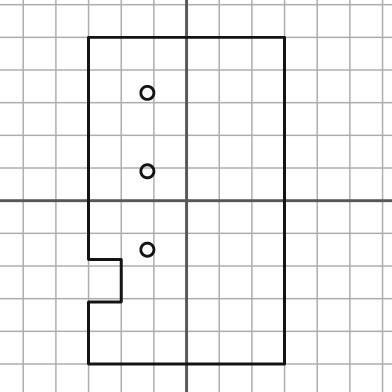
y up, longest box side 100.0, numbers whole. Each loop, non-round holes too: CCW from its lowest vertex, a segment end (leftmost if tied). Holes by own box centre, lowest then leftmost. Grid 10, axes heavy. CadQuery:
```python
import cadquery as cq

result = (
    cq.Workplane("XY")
    .moveTo(-30.0, -50.0)
    .lineTo(30.0, -50.0)
    .lineTo(30.0, 50.0)
    .lineTo(-30.0, 50.0)
    .lineTo(-30.0, -18.0)
    .lineTo(-20.0, -18.0)
    .lineTo(-20.0, -31.0)
    .lineTo(-30.0, -31.0)
    .close()
    .moveTo(-12.0, -15.0)
    .circle(2.0)
    .moveTo(-12.0, 9.0)
    .circle(2.0)
    .moveTo(-12.0, 33.0)
    .circle(2.0)
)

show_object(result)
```